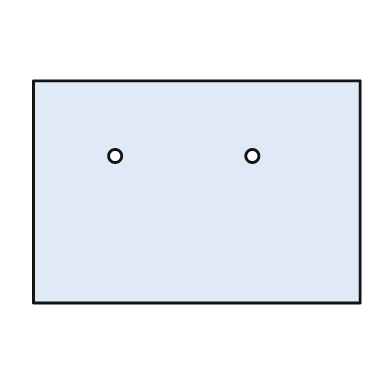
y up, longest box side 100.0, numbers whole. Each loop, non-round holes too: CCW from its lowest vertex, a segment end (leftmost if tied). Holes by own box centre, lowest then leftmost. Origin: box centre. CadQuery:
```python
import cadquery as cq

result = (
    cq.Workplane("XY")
    .moveTo(-50.0, -34.0)
    .lineTo(50.0, -34.0)
    .lineTo(50.0, 34.0)
    .lineTo(-50.0, 34.0)
    .close()
    .moveTo(-25.0, 11.0)
    .circle(2.0)
    .moveTo(17.0, 11.0)
    .circle(2.0)
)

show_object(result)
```